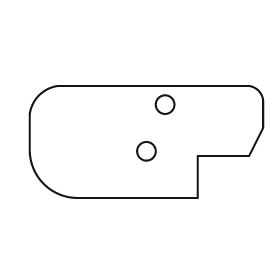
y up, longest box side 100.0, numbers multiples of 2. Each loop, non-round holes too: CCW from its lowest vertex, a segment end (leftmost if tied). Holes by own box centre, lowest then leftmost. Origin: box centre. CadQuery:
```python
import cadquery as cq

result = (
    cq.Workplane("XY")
    .moveTo(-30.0, -24.0)
    .lineTo(22.0, -24.0)
    .lineTo(22.0, -6.0)
    .lineTo(44.0, -6.0)
    .lineTo(50.0, 6.0)
    .lineTo(50.0, 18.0)
    .threePointArc((48.0, 22.0), (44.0, 24.0))
    .lineTo(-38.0, 24.0)
    .threePointArc((-46.0, 20.0), (-50.0, 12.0))
    .lineTo(-50.0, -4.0)
    .threePointArc((-44.0, -18.0), (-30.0, -24.0))
    .close()
    .moveTo(0.0, -4.0)
    .circle(4.0)
    .moveTo(8.0, 16.0)
    .circle(4.0)
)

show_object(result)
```